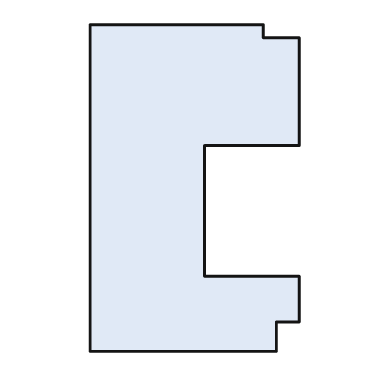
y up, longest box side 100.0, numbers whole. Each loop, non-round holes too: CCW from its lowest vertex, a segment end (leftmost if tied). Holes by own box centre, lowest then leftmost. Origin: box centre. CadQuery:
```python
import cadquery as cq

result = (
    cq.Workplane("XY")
    .moveTo(-32.0, -50.0)
    .lineTo(25.0, -50.0)
    .lineTo(25.0, -41.0)
    .lineTo(32.0, -41.0)
    .lineTo(32.0, -27.0)
    .lineTo(3.0, -27.0)
    .lineTo(3.0, 13.0)
    .lineTo(32.0, 13.0)
    .lineTo(32.0, 46.0)
    .lineTo(21.0, 46.0)
    .lineTo(21.0, 50.0)
    .lineTo(-32.0, 50.0)
    .close()
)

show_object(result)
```